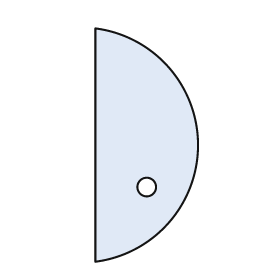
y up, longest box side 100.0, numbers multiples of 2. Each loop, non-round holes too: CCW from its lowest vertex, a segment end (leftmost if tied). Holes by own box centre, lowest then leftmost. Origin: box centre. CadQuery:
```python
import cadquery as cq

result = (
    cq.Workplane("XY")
    .moveTo(-22.0, -50.0)
    .threePointArc((22.0, 0.0), (-22.0, 50.0))
    .close()
    .moveTo(0.0, -18.0)
    .circle(4.0)
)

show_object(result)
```